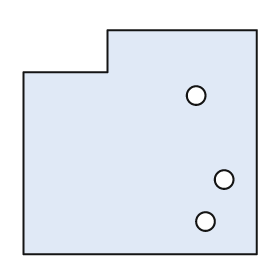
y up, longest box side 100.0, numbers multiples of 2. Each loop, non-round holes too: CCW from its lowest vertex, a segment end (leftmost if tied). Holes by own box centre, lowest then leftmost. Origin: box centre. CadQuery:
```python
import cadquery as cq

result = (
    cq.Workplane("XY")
    .moveTo(-50.0, -48.0)
    .lineTo(50.0, -48.0)
    .lineTo(50.0, 48.0)
    .lineTo(-14.0, 48.0)
    .lineTo(-14.0, 30.0)
    .lineTo(-50.0, 30.0)
    .close()
    .moveTo(28.0, -34.0)
    .circle(4.0)
    .moveTo(36.0, -16.0)
    .circle(4.0)
    .moveTo(24.0, 20.0)
    .circle(4.0)
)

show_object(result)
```